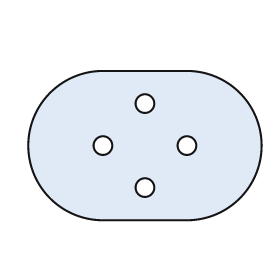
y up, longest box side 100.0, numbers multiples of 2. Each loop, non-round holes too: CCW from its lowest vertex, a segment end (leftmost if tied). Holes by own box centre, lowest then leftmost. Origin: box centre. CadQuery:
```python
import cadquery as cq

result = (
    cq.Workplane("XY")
    .moveTo(-18.0, -32.0)
    .lineTo(18.0, -32.0)
    .threePointArc((50.0, 0.0), (18.0, 32.0))
    .lineTo(-18.0, 32.0)
    .threePointArc((-50.0, 0.0), (-18.0, -32.0))
    .close()
    .moveTo(0.0, -18.0)
    .circle(4.0)
    .moveTo(-18.0, 0.0)
    .circle(4.0)
    .moveTo(18.0, 0.0)
    .circle(4.0)
    .moveTo(0.0, 18.0)
    .circle(4.0)
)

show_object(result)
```